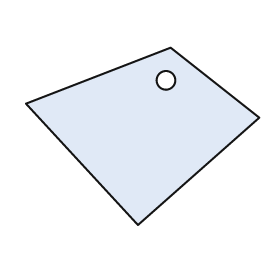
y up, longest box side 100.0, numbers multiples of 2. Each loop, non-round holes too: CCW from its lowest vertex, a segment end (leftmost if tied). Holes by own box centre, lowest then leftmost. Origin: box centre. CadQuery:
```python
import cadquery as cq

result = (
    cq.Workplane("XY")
    .moveTo(-2.0, -38.0)
    .lineTo(50.0, 8.0)
    .lineTo(12.0, 38.0)
    .lineTo(-50.0, 14.0)
    .close()
    .moveTo(10.0, 24.0)
    .circle(4.0)
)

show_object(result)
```